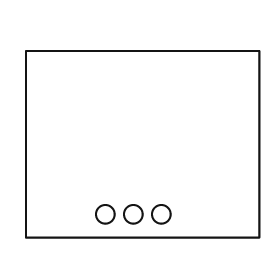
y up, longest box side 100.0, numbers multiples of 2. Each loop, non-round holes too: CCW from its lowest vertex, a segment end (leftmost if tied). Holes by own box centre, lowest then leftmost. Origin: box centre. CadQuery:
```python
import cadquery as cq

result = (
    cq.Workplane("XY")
    .moveTo(-50.0, -40.0)
    .lineTo(50.0, -40.0)
    .lineTo(50.0, 40.0)
    .lineTo(-50.0, 40.0)
    .close()
    .moveTo(-16.0, -30.0)
    .circle(4.0)
    .moveTo(-4.0, -30.0)
    .circle(4.0)
    .moveTo(8.0, -30.0)
    .circle(4.0)
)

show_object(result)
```